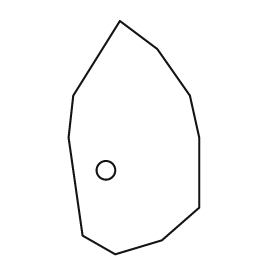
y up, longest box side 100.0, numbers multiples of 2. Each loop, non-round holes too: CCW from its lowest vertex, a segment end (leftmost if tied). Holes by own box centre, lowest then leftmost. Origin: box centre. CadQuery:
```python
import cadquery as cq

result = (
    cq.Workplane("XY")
    .moveTo(-8.0, -50.0)
    .lineTo(12.0, -44.0)
    .lineTo(28.0, -30.0)
    .lineTo(28.0, 0.0)
    .lineTo(24.0, 18.0)
    .lineTo(10.0, 38.0)
    .lineTo(-6.0, 50.0)
    .lineTo(-26.0, 18.0)
    .lineTo(-28.0, 0.0)
    .lineTo(-22.0, -42.0)
    .close()
    .moveTo(-12.0, -14.0)
    .circle(4.0)
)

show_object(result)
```